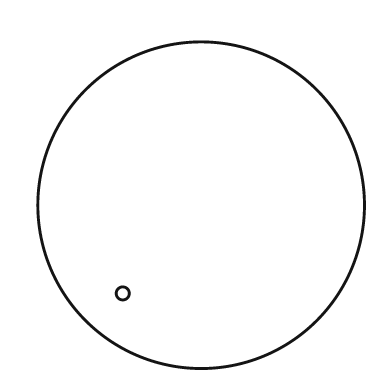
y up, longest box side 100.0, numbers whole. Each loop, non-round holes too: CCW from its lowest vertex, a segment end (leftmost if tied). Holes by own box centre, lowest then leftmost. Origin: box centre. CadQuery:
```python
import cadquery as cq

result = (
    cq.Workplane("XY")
    .moveTo(0.0, 0.0)
    .circle(50.0)
    .moveTo(-24.0, -27.0)
    .circle(2.0)
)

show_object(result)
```